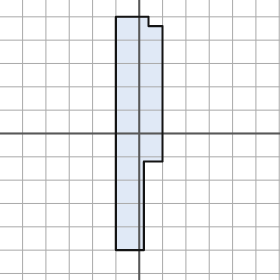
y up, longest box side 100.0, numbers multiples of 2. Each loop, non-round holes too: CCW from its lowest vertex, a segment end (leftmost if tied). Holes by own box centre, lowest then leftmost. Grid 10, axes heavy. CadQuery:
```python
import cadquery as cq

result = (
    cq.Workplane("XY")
    .moveTo(-10.0, -50.0)
    .lineTo(2.0, -50.0)
    .lineTo(2.0, -12.0)
    .lineTo(10.0, -12.0)
    .lineTo(10.0, 46.0)
    .lineTo(4.0, 46.0)
    .lineTo(4.0, 50.0)
    .lineTo(-10.0, 50.0)
    .close()
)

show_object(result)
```